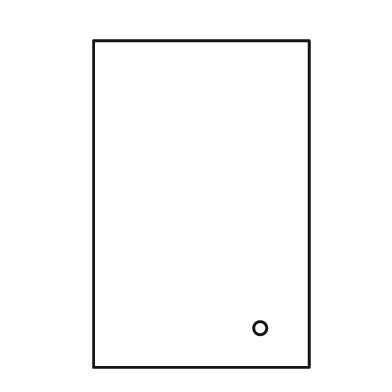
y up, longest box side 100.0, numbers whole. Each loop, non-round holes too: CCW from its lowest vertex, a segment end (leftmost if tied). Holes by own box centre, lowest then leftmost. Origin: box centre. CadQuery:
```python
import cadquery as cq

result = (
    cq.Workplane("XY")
    .moveTo(-33.0, -50.0)
    .lineTo(33.0, -50.0)
    .lineTo(33.0, 50.0)
    .lineTo(-33.0, 50.0)
    .close()
    .moveTo(18.0, -38.0)
    .circle(2.0)
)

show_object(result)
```